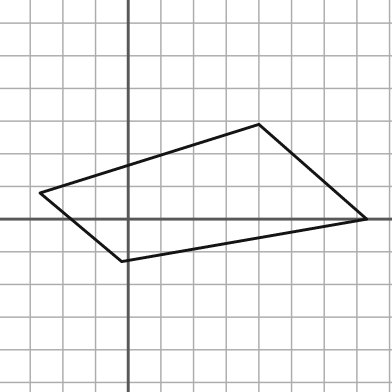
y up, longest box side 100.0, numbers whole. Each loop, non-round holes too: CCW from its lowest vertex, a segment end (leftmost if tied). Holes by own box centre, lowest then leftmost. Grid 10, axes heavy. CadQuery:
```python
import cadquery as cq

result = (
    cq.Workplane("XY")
    .moveTo(-2.0, -13.0)
    .lineTo(73.0, 0.0)
    .lineTo(40.0, 29.0)
    .lineTo(-27.0, 8.0)
    .close()
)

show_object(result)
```